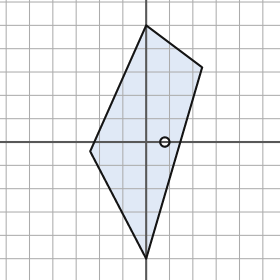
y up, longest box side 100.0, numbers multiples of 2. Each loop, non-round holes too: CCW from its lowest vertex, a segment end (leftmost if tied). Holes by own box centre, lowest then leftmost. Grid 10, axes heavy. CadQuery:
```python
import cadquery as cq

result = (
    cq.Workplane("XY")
    .moveTo(0.0, -50.0)
    .lineTo(24.0, 32.0)
    .lineTo(0.0, 50.0)
    .lineTo(-24.0, -4.0)
    .close()
    .moveTo(8.0, 0.0)
    .circle(2.0)
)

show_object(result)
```